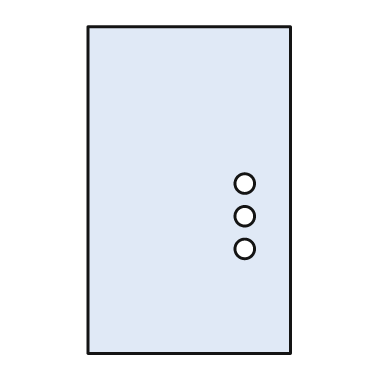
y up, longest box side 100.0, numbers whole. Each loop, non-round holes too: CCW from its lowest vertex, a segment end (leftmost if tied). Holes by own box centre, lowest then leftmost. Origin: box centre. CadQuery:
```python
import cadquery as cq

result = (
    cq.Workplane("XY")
    .moveTo(-31.0, -50.0)
    .lineTo(31.0, -50.0)
    .lineTo(31.0, 50.0)
    .lineTo(-31.0, 50.0)
    .close()
    .moveTo(17.0, -18.0)
    .circle(3.0)
    .moveTo(17.0, -8.0)
    .circle(3.0)
    .moveTo(17.0, 2.0)
    .circle(3.0)
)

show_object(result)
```